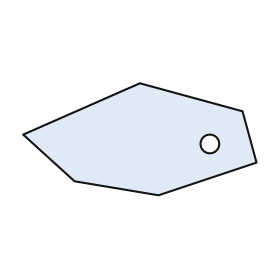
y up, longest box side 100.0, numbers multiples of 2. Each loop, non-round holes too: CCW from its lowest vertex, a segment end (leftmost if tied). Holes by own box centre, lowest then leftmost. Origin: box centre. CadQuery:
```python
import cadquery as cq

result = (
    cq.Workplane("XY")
    .moveTo(8.0, -24.0)
    .lineTo(50.0, -10.0)
    .lineTo(44.0, 12.0)
    .lineTo(0.0, 24.0)
    .lineTo(-50.0, 2.0)
    .lineTo(-28.0, -18.0)
    .close()
    .moveTo(30.0, -2.0)
    .circle(4.0)
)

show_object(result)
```